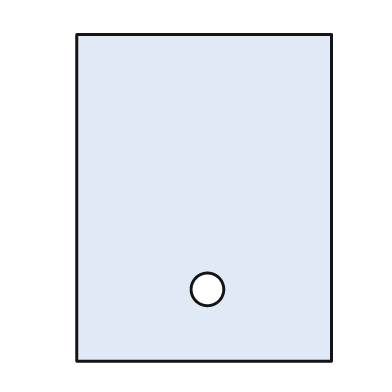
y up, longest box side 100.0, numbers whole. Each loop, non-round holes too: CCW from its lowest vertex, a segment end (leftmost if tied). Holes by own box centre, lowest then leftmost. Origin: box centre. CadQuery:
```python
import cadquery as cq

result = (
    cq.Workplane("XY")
    .moveTo(-39.0, -50.0)
    .lineTo(39.0, -50.0)
    .lineTo(39.0, 50.0)
    .lineTo(-39.0, 50.0)
    .close()
    .moveTo(1.0, -28.0)
    .circle(5.0)
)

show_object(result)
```